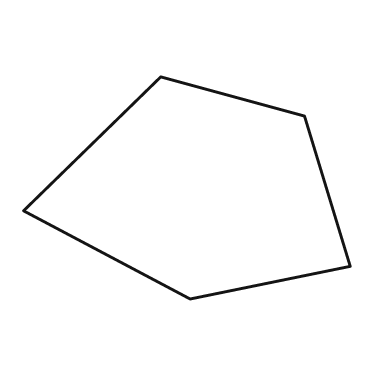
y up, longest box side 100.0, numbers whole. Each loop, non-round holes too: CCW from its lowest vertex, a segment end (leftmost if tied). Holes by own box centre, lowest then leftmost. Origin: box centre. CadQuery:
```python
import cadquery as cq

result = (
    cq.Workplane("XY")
    .moveTo(1.0, -34.0)
    .lineTo(50.0, -24.0)
    .lineTo(36.0, 22.0)
    .lineTo(-8.0, 34.0)
    .lineTo(-50.0, -7.0)
    .close()
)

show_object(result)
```